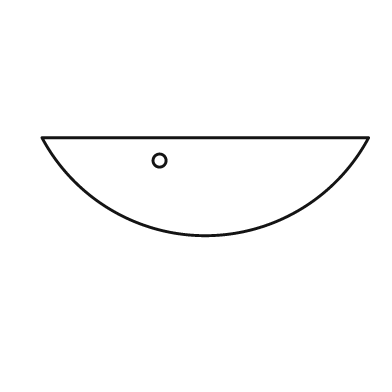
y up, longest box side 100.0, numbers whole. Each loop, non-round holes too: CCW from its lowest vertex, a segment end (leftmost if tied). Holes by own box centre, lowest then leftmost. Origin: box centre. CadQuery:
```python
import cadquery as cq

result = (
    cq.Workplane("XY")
    .moveTo(-50.0, 15.0)
    .threePointArc((0.0, -15.0), (50.0, 15.0))
    .close()
    .moveTo(-14.0, 8.0)
    .circle(2.0)
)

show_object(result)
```